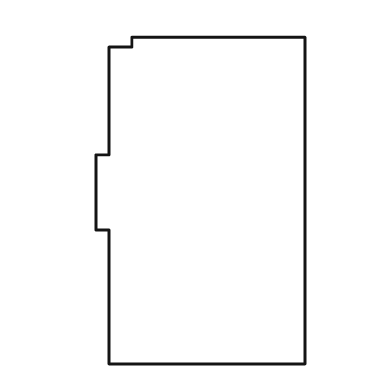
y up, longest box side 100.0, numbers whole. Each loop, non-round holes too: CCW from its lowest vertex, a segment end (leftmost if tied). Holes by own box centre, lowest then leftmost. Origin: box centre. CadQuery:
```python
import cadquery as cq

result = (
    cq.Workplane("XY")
    .moveTo(-28.0, -50.0)
    .lineTo(32.0, -50.0)
    .lineTo(32.0, 50.0)
    .lineTo(-21.0, 50.0)
    .lineTo(-21.0, 47.0)
    .lineTo(-28.0, 47.0)
    .lineTo(-28.0, 14.0)
    .lineTo(-32.0, 14.0)
    .lineTo(-32.0, -9.0)
    .lineTo(-28.0, -9.0)
    .close()
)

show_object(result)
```